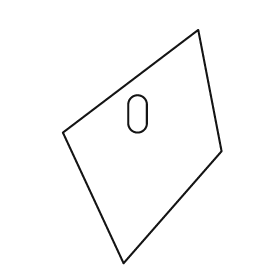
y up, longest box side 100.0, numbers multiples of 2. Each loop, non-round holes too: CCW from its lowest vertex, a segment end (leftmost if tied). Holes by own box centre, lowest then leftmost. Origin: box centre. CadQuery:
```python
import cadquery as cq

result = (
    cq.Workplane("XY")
    .moveTo(-8.0, -50.0)
    .lineTo(34.0, -2.0)
    .lineTo(24.0, 50.0)
    .lineTo(-34.0, 6.0)
    .close()
    .moveTo(-6.0, 10.0)
    .threePointArc((-2.0, 6.0), (2.0, 10.0))
    .lineTo(2.0, 18.0)
    .threePointArc((-2.0, 22.0), (-6.0, 18.0))
    .close()
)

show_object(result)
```